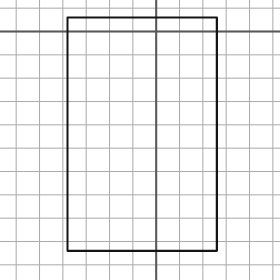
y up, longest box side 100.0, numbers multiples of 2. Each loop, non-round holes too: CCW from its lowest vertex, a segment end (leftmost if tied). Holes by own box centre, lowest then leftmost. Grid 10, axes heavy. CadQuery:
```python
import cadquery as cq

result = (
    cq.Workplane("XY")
    .moveTo(-38.0, -94.0)
    .lineTo(26.0, -94.0)
    .lineTo(26.0, 6.0)
    .lineTo(-38.0, 6.0)
    .close()
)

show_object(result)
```